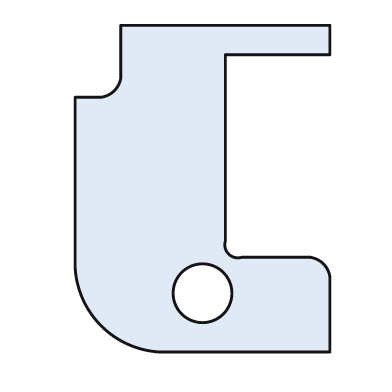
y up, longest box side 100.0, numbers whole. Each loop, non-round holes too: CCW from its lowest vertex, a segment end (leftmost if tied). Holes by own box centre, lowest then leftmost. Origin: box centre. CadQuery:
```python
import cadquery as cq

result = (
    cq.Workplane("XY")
    .moveTo(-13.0, -50.0)
    .lineTo(39.0, -50.0)
    .lineTo(39.0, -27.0)
    .threePointArc((37.0, -23.0), (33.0, -21.0))
    .lineTo(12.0, -21.0)
    .threePointArc((8.0, -20.0), (7.0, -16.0))
    .lineTo(7.0, 41.0)
    .lineTo(39.0, 41.0)
    .lineTo(39.0, 50.0)
    .lineTo(-25.0, 50.0)
    .lineTo(-25.0, 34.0)
    .threePointArc((-27.0, 30.0), (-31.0, 28.0))
    .lineTo(-39.0, 28.0)
    .lineTo(-39.0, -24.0)
    .threePointArc((-31.0, -42.0), (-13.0, -50.0))
    .close()
    .moveTo(0.0, -32.0)
    .circle(9.0)
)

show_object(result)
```